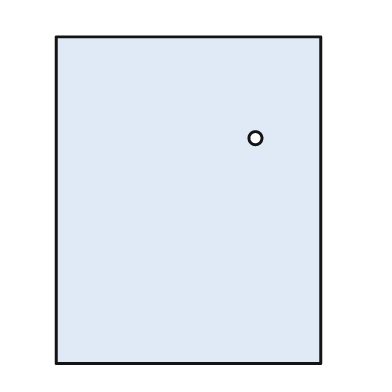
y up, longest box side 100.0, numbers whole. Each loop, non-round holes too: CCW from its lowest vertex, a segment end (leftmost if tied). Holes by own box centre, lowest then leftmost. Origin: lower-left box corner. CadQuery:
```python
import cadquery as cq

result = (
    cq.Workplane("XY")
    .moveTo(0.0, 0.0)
    .lineTo(81.0, 0.0)
    .lineTo(81.0, 100.0)
    .lineTo(0.0, 100.0)
    .close()
    .moveTo(61.0, 69.0)
    .circle(2.0)
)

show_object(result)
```